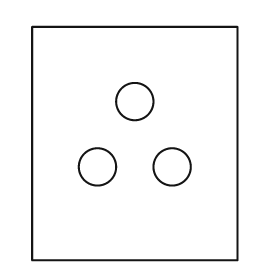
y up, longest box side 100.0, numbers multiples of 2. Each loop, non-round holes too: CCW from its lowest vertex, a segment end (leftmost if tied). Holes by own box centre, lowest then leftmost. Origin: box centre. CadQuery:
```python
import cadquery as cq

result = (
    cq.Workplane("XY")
    .moveTo(-44.0, -50.0)
    .lineTo(44.0, -50.0)
    .lineTo(44.0, 50.0)
    .lineTo(-44.0, 50.0)
    .close()
    .moveTo(-16.0, -10.0)
    .circle(8.0)
    .moveTo(16.0, -10.0)
    .circle(8.0)
    .moveTo(0.0, 18.0)
    .circle(8.0)
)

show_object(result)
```